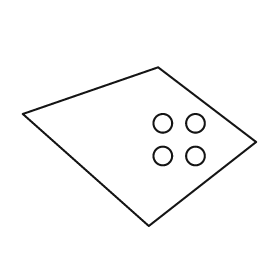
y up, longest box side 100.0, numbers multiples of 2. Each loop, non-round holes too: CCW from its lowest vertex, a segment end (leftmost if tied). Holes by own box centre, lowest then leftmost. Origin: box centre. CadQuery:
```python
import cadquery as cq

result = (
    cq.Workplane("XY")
    .moveTo(4.0, -34.0)
    .lineTo(50.0, 2.0)
    .lineTo(8.0, 34.0)
    .lineTo(-50.0, 14.0)
    .close()
    .moveTo(10.0, -4.0)
    .circle(4.0)
    .moveTo(24.0, -4.0)
    .circle(4.0)
    .moveTo(10.0, 10.0)
    .circle(4.0)
    .moveTo(24.0, 10.0)
    .circle(4.0)
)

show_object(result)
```